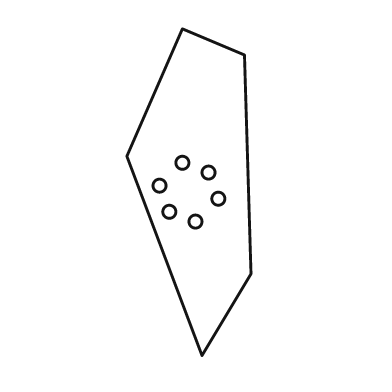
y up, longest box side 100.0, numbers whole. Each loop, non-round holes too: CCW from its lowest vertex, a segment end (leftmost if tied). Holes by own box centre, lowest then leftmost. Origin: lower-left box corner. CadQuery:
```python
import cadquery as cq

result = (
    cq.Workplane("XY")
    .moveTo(23.0, 0.0)
    .lineTo(38.0, 25.0)
    .lineTo(36.0, 92.0)
    .lineTo(17.0, 100.0)
    .lineTo(0.0, 61.0)
    .close()
    .moveTo(21.0, 41.0)
    .circle(2.0)
    .moveTo(13.0, 44.0)
    .circle(2.0)
    .moveTo(28.0, 48.0)
    .circle(2.0)
    .moveTo(10.0, 52.0)
    .circle(2.0)
    .moveTo(25.0, 56.0)
    .circle(2.0)
    .moveTo(17.0, 59.0)
    .circle(2.0)
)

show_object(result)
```